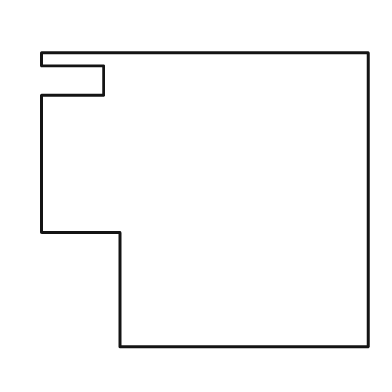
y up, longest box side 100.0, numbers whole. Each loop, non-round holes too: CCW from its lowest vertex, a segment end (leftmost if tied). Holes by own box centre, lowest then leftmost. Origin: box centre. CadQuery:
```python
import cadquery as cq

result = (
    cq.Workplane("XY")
    .moveTo(-26.0, -45.0)
    .lineTo(50.0, -45.0)
    .lineTo(50.0, 45.0)
    .lineTo(-50.0, 45.0)
    .lineTo(-50.0, 41.0)
    .lineTo(-31.0, 41.0)
    .lineTo(-31.0, 32.0)
    .lineTo(-50.0, 32.0)
    .lineTo(-50.0, -10.0)
    .lineTo(-26.0, -10.0)
    .close()
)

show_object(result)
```